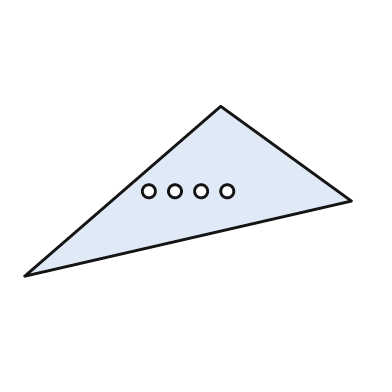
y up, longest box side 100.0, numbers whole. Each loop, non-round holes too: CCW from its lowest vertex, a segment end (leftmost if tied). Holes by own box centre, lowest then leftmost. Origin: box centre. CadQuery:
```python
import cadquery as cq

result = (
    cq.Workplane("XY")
    .moveTo(-50.0, -26.0)
    .lineTo(50.0, -3.0)
    .lineTo(10.0, 26.0)
    .close()
    .moveTo(-12.0, 0.0)
    .circle(2.0)
    .moveTo(-4.0, 0.0)
    .circle(2.0)
    .moveTo(4.0, 0.0)
    .circle(2.0)
    .moveTo(12.0, 0.0)
    .circle(2.0)
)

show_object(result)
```